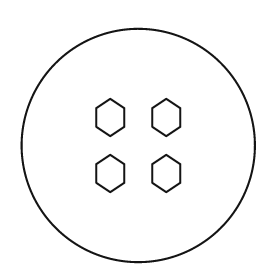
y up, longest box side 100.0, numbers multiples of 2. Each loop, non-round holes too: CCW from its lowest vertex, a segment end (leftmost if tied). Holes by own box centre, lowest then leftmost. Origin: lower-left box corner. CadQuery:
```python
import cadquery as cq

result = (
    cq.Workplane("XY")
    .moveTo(50.0, 50.0)
    .circle(50.0)
    .moveTo(38.0, 30.0)
    .lineTo(44.0, 34.0)
    .lineTo(44.0, 42.0)
    .lineTo(38.0, 46.0)
    .lineTo(32.0, 42.0)
    .lineTo(32.0, 34.0)
    .close()
    .moveTo(62.0, 30.0)
    .lineTo(68.0, 34.0)
    .lineTo(68.0, 42.0)
    .lineTo(62.0, 46.0)
    .lineTo(56.0, 42.0)
    .lineTo(56.0, 34.0)
    .close()
    .moveTo(38.0, 54.0)
    .lineTo(44.0, 58.0)
    .lineTo(44.0, 66.0)
    .lineTo(38.0, 70.0)
    .lineTo(32.0, 66.0)
    .lineTo(32.0, 58.0)
    .close()
    .moveTo(62.0, 54.0)
    .lineTo(68.0, 58.0)
    .lineTo(68.0, 66.0)
    .lineTo(62.0, 70.0)
    .lineTo(56.0, 66.0)
    .lineTo(56.0, 58.0)
    .close()
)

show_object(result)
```